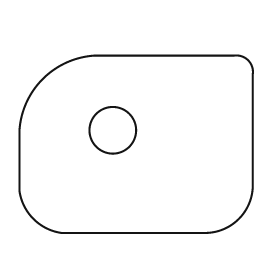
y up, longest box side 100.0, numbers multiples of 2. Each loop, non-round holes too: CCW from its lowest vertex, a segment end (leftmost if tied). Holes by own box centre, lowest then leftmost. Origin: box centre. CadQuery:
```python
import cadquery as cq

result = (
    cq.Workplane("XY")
    .moveTo(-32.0, -38.0)
    .lineTo(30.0, -38.0)
    .threePointArc((44.0, -32.0), (50.0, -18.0))
    .lineTo(50.0, 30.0)
    .threePointArc((48.0, 36.0), (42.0, 38.0))
    .lineTo(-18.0, 38.0)
    .threePointArc((-40.0, 28.0), (-50.0, 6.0))
    .lineTo(-50.0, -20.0)
    .threePointArc((-44.0, -32.0), (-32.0, -38.0))
    .close()
    .moveTo(-10.0, 6.0)
    .circle(10.0)
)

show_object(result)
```